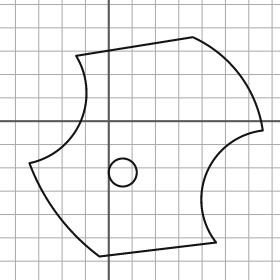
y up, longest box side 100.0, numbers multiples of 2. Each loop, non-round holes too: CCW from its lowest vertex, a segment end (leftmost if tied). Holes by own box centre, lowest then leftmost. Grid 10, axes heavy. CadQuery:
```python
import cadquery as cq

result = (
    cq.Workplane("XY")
    .moveTo(-4.0, -58.0)
    .lineTo(46.0, -52.0)
    .threePointArc((42.0, -22.0), (66.0, -4.0))
    .threePointArc((56.0, 20.0), (36.0, 36.0))
    .lineTo(-14.0, 28.0)
    .threePointArc((-12.0, 0.0), (-34.0, -18.0))
    .threePointArc((-22.0, -40.0), (-4.0, -58.0))
    .close()
    .moveTo(6.0, -22.0)
    .circle(6.0)
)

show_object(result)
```